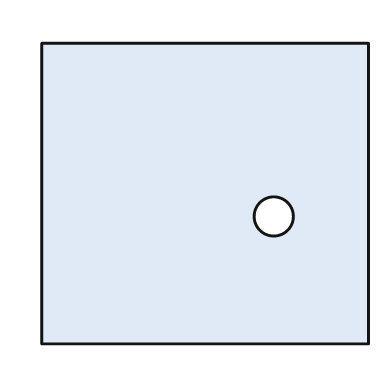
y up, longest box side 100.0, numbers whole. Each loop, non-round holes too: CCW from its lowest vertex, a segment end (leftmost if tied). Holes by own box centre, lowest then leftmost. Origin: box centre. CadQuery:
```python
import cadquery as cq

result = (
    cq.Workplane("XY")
    .moveTo(-50.0, -46.0)
    .lineTo(50.0, -46.0)
    .lineTo(50.0, 46.0)
    .lineTo(-50.0, 46.0)
    .close()
    .moveTo(21.0, -7.0)
    .circle(6.0)
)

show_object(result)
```